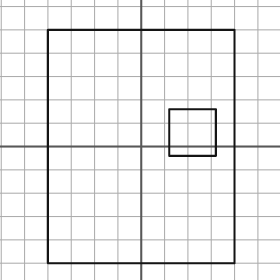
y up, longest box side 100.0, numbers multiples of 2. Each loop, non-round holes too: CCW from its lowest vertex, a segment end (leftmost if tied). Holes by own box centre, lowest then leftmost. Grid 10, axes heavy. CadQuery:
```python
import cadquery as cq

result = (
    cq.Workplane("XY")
    .moveTo(-40.0, -50.0)
    .lineTo(40.0, -50.0)
    .lineTo(40.0, 50.0)
    .lineTo(-40.0, 50.0)
    .close()
    .moveTo(12.0, -4.0)
    .lineTo(32.0, -4.0)
    .lineTo(32.0, 16.0)
    .lineTo(12.0, 16.0)
    .close()
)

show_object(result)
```